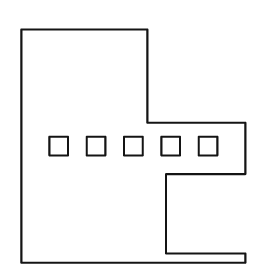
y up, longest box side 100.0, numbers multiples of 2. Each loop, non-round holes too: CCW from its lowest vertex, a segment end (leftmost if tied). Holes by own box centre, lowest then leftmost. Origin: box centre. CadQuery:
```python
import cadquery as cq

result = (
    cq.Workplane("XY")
    .moveTo(-48.0, -50.0)
    .lineTo(48.0, -50.0)
    .lineTo(48.0, -46.0)
    .lineTo(14.0, -46.0)
    .lineTo(14.0, -12.0)
    .lineTo(48.0, -12.0)
    .lineTo(48.0, 10.0)
    .lineTo(6.0, 10.0)
    .lineTo(6.0, 50.0)
    .lineTo(-48.0, 50.0)
    .close()
    .moveTo(-36.0, -4.0)
    .lineTo(-28.0, -4.0)
    .lineTo(-28.0, 4.0)
    .lineTo(-36.0, 4.0)
    .close()
    .moveTo(-20.0, -4.0)
    .lineTo(-12.0, -4.0)
    .lineTo(-12.0, 4.0)
    .lineTo(-20.0, 4.0)
    .close()
    .moveTo(-4.0, -4.0)
    .lineTo(4.0, -4.0)
    .lineTo(4.0, 4.0)
    .lineTo(-4.0, 4.0)
    .close()
    .moveTo(12.0, -4.0)
    .lineTo(20.0, -4.0)
    .lineTo(20.0, 4.0)
    .lineTo(12.0, 4.0)
    .close()
    .moveTo(28.0, -4.0)
    .lineTo(36.0, -4.0)
    .lineTo(36.0, 4.0)
    .lineTo(28.0, 4.0)
    .close()
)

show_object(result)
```